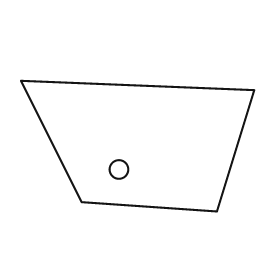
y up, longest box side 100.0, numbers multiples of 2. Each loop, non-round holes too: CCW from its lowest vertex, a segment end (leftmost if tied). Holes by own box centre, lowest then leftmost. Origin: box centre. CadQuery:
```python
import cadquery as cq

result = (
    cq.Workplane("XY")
    .moveTo(34.0, -28.0)
    .lineTo(50.0, 24.0)
    .lineTo(-50.0, 28.0)
    .lineTo(-24.0, -24.0)
    .close()
    .moveTo(-8.0, -10.0)
    .circle(4.0)
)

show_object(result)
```